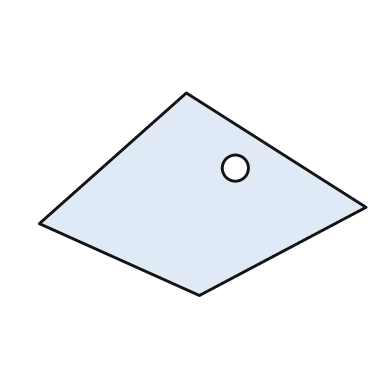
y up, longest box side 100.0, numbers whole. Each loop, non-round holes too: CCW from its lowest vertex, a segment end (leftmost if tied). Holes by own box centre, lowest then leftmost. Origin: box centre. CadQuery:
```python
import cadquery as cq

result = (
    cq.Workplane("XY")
    .moveTo(-1.0, -31.0)
    .lineTo(50.0, -4.0)
    .lineTo(-5.0, 31.0)
    .lineTo(-50.0, -9.0)
    .close()
    .moveTo(10.0, 8.0)
    .circle(4.0)
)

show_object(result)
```